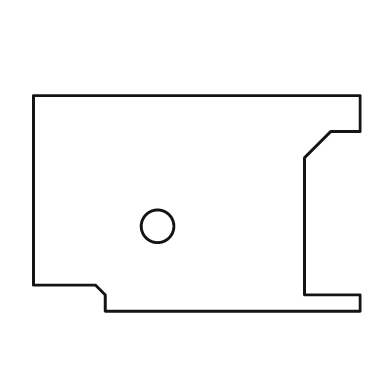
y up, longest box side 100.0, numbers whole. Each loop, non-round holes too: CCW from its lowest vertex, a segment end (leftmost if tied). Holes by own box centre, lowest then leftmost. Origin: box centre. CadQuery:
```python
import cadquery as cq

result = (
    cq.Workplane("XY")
    .moveTo(-28.0, -33.0)
    .lineTo(50.0, -33.0)
    .lineTo(50.0, -28.0)
    .lineTo(33.0, -28.0)
    .lineTo(33.0, 14.0)
    .lineTo(41.0, 22.0)
    .lineTo(50.0, 22.0)
    .lineTo(50.0, 33.0)
    .lineTo(-50.0, 33.0)
    .lineTo(-50.0, -25.0)
    .lineTo(-31.0, -25.0)
    .lineTo(-28.0, -28.0)
    .close()
    .moveTo(-12.0, -7.0)
    .circle(5.0)
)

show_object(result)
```